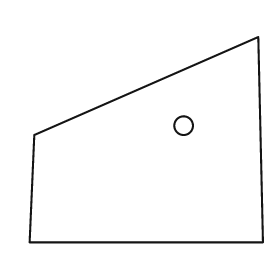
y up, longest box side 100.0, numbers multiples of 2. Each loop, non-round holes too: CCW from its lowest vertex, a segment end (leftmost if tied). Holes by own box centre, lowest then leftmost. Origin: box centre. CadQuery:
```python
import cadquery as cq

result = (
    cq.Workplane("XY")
    .moveTo(-50.0, -44.0)
    .lineTo(50.0, -44.0)
    .lineTo(48.0, 44.0)
    .lineTo(-48.0, 2.0)
    .close()
    .moveTo(16.0, 6.0)
    .circle(4.0)
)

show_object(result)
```